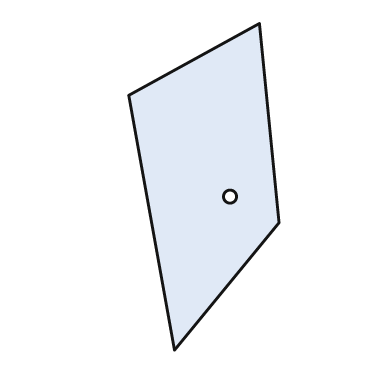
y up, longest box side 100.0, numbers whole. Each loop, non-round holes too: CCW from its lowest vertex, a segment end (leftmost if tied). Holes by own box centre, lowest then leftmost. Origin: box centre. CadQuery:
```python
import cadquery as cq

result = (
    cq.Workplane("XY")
    .moveTo(-9.0, -50.0)
    .lineTo(23.0, -11.0)
    .lineTo(17.0, 50.0)
    .lineTo(-23.0, 28.0)
    .close()
    .moveTo(8.0, -3.0)
    .circle(2.0)
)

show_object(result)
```